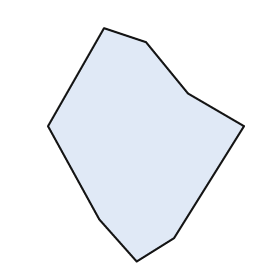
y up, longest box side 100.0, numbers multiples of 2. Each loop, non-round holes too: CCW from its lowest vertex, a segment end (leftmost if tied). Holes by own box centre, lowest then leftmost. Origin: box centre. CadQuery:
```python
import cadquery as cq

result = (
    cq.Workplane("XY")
    .moveTo(-4.0, -50.0)
    .lineTo(12.0, -40.0)
    .lineTo(42.0, 8.0)
    .lineTo(18.0, 22.0)
    .lineTo(0.0, 44.0)
    .lineTo(-18.0, 50.0)
    .lineTo(-42.0, 8.0)
    .lineTo(-20.0, -32.0)
    .close()
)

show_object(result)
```